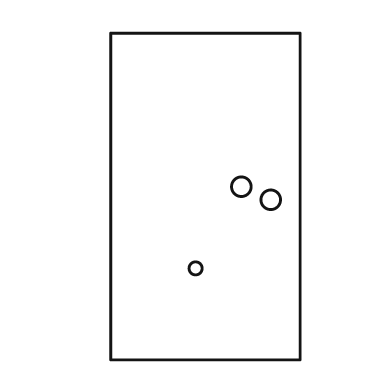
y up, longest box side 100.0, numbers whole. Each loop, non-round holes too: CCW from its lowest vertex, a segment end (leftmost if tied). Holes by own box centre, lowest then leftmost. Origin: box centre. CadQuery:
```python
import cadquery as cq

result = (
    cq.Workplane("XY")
    .moveTo(-29.0, -50.0)
    .lineTo(29.0, -50.0)
    .lineTo(29.0, 50.0)
    .lineTo(-29.0, 50.0)
    .close()
    .moveTo(-3.0, -22.0)
    .circle(2.0)
    .moveTo(20.0, -1.0)
    .circle(3.0)
    .moveTo(11.0, 3.0)
    .circle(3.0)
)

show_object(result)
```